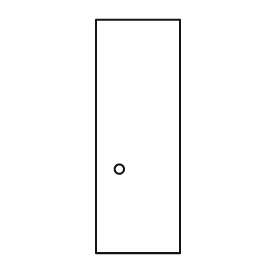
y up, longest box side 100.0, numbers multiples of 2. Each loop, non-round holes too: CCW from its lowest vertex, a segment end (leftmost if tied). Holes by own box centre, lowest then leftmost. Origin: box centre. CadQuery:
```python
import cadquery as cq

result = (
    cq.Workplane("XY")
    .moveTo(-18.0, -50.0)
    .lineTo(18.0, -50.0)
    .lineTo(18.0, 50.0)
    .lineTo(-18.0, 50.0)
    .close()
    .moveTo(-8.0, -14.0)
    .circle(2.0)
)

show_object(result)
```